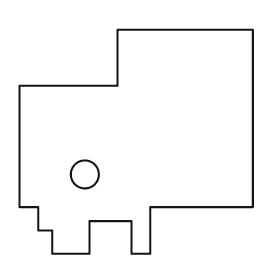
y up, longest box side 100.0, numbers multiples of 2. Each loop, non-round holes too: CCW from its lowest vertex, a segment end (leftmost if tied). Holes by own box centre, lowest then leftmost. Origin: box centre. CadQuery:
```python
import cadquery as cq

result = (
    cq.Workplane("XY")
    .moveTo(-36.0, -48.0)
    .lineTo(-20.0, -48.0)
    .lineTo(-20.0, -34.0)
    .lineTo(-2.0, -34.0)
    .lineTo(-2.0, -48.0)
    .lineTo(6.0, -48.0)
    .lineTo(6.0, -28.0)
    .lineTo(50.0, -28.0)
    .lineTo(50.0, 48.0)
    .lineTo(-8.0, 48.0)
    .lineTo(-8.0, 24.0)
    .lineTo(-50.0, 24.0)
    .lineTo(-50.0, -28.0)
    .lineTo(-42.0, -28.0)
    .lineTo(-42.0, -38.0)
    .lineTo(-36.0, -38.0)
    .close()
    .moveTo(-22.0, -14.0)
    .circle(6.0)
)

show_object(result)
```